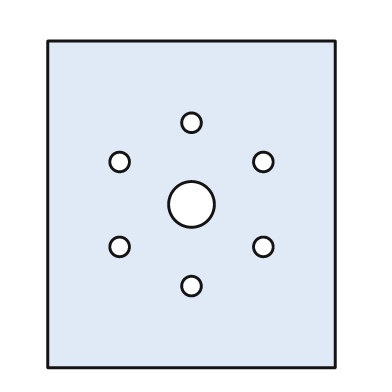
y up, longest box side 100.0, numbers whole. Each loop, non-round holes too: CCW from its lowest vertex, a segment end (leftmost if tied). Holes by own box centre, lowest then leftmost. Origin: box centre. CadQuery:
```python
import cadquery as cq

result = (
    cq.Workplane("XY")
    .moveTo(-44.0, -50.0)
    .lineTo(44.0, -50.0)
    .lineTo(44.0, 50.0)
    .lineTo(-44.0, 50.0)
    .close()
    .moveTo(0.0, -25.0)
    .circle(3.0)
    .moveTo(-22.0, -13.0)
    .circle(3.0)
    .moveTo(22.0, -13.0)
    .circle(3.0)
    .moveTo(0.0, 0.0)
    .circle(7.0)
    .moveTo(-22.0, 13.0)
    .circle(3.0)
    .moveTo(22.0, 13.0)
    .circle(3.0)
    .moveTo(0.0, 25.0)
    .circle(3.0)
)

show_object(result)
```